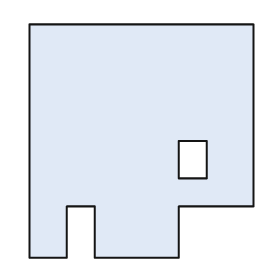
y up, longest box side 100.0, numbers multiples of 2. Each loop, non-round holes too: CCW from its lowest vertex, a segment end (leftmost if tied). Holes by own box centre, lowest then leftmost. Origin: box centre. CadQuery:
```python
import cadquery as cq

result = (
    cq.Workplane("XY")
    .moveTo(-48.0, -50.0)
    .lineTo(-32.0, -50.0)
    .lineTo(-32.0, -28.0)
    .lineTo(-20.0, -28.0)
    .lineTo(-20.0, -50.0)
    .lineTo(16.0, -50.0)
    .lineTo(16.0, -28.0)
    .lineTo(48.0, -28.0)
    .lineTo(48.0, 50.0)
    .lineTo(-48.0, 50.0)
    .close()
    .moveTo(16.0, -16.0)
    .lineTo(28.0, -16.0)
    .lineTo(28.0, 0.0)
    .lineTo(16.0, 0.0)
    .close()
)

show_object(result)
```